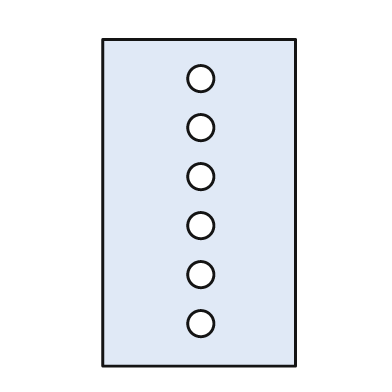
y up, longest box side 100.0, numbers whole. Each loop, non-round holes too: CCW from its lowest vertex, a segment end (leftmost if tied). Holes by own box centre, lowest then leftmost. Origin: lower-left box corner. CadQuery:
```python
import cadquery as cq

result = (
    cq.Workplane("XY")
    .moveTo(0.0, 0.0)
    .lineTo(59.0, 0.0)
    .lineTo(59.0, 100.0)
    .lineTo(0.0, 100.0)
    .close()
    .moveTo(30.0, 13.0)
    .circle(4.0)
    .moveTo(30.0, 28.0)
    .circle(4.0)
    .moveTo(30.0, 43.0)
    .circle(4.0)
    .moveTo(30.0, 58.0)
    .circle(4.0)
    .moveTo(30.0, 73.0)
    .circle(4.0)
    .moveTo(30.0, 88.0)
    .circle(4.0)
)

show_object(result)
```